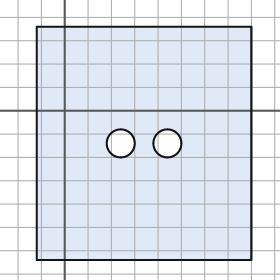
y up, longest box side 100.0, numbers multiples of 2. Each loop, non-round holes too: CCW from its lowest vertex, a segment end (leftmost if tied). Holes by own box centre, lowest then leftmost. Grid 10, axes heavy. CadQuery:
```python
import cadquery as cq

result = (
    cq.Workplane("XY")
    .moveTo(-12.0, -64.0)
    .lineTo(80.0, -64.0)
    .lineTo(80.0, 36.0)
    .lineTo(-12.0, 36.0)
    .close()
    .moveTo(24.0, -14.0)
    .circle(6.0)
    .moveTo(44.0, -14.0)
    .circle(6.0)
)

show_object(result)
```